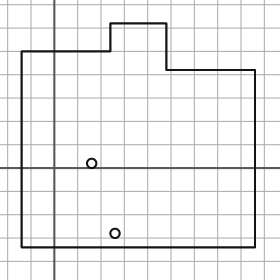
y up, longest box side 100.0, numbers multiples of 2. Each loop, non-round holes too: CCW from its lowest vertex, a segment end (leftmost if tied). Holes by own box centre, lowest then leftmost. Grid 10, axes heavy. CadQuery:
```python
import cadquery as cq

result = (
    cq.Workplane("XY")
    .moveTo(-14.0, -34.0)
    .lineTo(86.0, -34.0)
    .lineTo(86.0, 42.0)
    .lineTo(48.0, 42.0)
    .lineTo(48.0, 62.0)
    .lineTo(24.0, 62.0)
    .lineTo(24.0, 50.0)
    .lineTo(-14.0, 50.0)
    .close()
    .moveTo(26.0, -28.0)
    .circle(2.0)
    .moveTo(16.0, 2.0)
    .circle(2.0)
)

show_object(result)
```